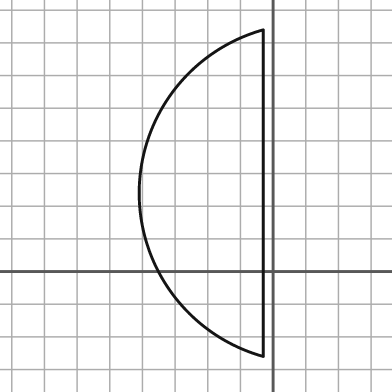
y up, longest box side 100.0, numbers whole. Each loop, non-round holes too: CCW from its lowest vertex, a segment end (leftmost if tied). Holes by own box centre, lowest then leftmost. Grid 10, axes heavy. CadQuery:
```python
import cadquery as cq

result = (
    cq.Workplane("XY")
    .moveTo(-3.0, -26.0)
    .lineTo(-3.0, 74.0)
    .threePointArc((-41.0, 24.0), (-3.0, -26.0))
    .close()
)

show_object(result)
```